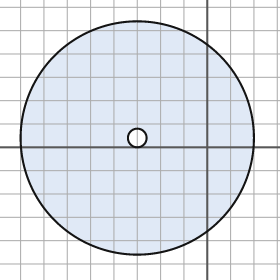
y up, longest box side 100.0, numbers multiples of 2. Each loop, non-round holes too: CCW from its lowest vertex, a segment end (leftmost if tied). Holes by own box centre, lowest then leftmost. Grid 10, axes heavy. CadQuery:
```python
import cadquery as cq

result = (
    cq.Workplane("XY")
    .moveTo(-30.0, 4.0)
    .circle(50.0)
    .moveTo(-30.0, 4.0)
    .circle(4.0)
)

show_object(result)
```